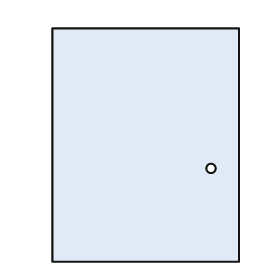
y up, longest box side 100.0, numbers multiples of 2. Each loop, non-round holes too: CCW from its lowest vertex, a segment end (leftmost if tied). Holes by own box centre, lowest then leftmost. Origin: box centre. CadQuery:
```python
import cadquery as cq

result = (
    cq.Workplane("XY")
    .moveTo(-40.0, -50.0)
    .lineTo(40.0, -50.0)
    .lineTo(40.0, 50.0)
    .lineTo(-40.0, 50.0)
    .close()
    .moveTo(28.0, -10.0)
    .circle(2.0)
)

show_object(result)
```